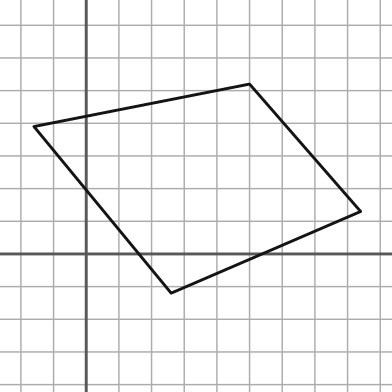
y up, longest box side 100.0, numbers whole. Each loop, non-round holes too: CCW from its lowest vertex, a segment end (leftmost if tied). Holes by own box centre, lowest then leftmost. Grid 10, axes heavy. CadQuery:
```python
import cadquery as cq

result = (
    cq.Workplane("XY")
    .moveTo(26.0, -12.0)
    .lineTo(84.0, 13.0)
    .lineTo(50.0, 52.0)
    .lineTo(-16.0, 39.0)
    .close()
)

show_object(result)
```